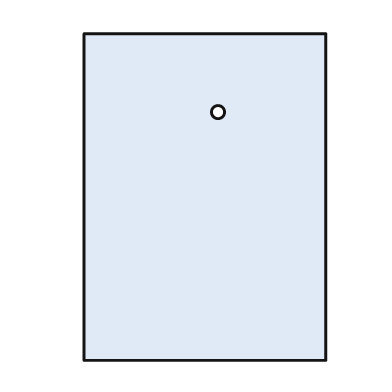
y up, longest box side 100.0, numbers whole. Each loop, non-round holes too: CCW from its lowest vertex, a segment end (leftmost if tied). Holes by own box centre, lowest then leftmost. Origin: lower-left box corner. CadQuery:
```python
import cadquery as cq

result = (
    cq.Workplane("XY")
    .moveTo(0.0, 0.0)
    .lineTo(74.0, 0.0)
    .lineTo(74.0, 100.0)
    .lineTo(0.0, 100.0)
    .close()
    .moveTo(41.0, 76.0)
    .circle(2.0)
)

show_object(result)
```